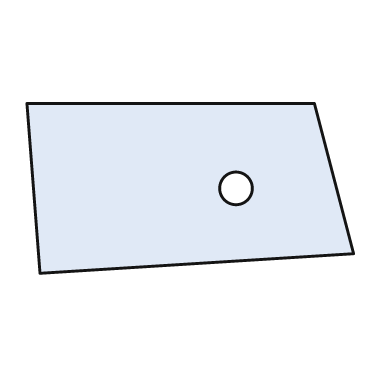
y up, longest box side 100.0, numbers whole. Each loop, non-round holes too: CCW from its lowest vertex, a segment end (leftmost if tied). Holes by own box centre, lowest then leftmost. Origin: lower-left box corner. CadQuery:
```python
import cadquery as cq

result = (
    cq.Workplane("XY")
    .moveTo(4.0, 0.0)
    .lineTo(100.0, 6.0)
    .lineTo(88.0, 52.0)
    .lineTo(0.0, 52.0)
    .close()
    .moveTo(64.0, 26.0)
    .circle(5.0)
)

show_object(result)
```